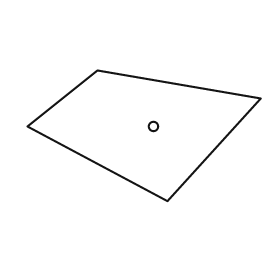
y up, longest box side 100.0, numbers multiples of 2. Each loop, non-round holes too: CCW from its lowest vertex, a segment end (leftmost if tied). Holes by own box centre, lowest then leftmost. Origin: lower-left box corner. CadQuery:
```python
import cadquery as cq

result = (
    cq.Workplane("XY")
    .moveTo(60.0, 0.0)
    .lineTo(100.0, 44.0)
    .lineTo(30.0, 56.0)
    .lineTo(0.0, 32.0)
    .close()
    .moveTo(54.0, 32.0)
    .circle(2.0)
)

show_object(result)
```